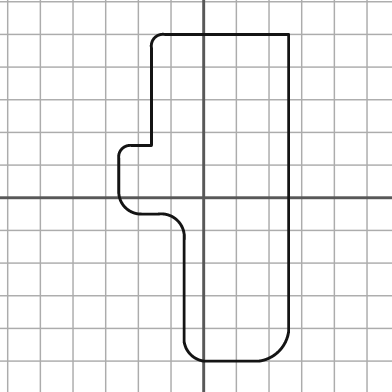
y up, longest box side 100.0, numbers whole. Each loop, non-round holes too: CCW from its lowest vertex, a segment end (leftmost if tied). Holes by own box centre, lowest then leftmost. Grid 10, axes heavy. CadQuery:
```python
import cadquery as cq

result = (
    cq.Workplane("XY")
    .moveTo(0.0, -50.0)
    .lineTo(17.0, -50.0)
    .threePointArc((23.0, -47.0), (26.0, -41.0))
    .lineTo(26.0, 50.0)
    .lineTo(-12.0, 50.0)
    .threePointArc((-15.0, 49.0), (-16.0, 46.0))
    .lineTo(-16.0, 16.0)
    .lineTo(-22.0, 16.0)
    .threePointArc((-25.0, 15.0), (-26.0, 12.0))
    .lineTo(-26.0, 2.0)
    .threePointArc((-24.0, -3.0), (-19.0, -5.0))
    .lineTo(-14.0, -5.0)
    .threePointArc((-8.0, -7.0), (-6.0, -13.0))
    .lineTo(-6.0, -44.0)
    .threePointArc((-4.0, -48.0), (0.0, -50.0))
    .close()
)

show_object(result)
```